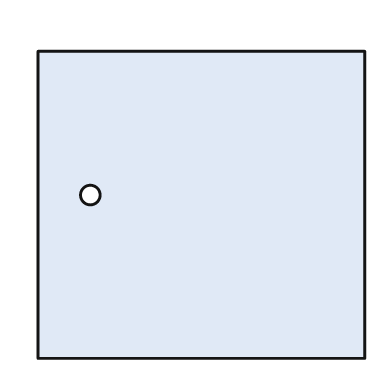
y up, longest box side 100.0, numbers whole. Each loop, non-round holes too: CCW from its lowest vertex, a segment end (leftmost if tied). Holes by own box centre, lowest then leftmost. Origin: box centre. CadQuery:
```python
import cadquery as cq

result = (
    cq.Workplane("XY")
    .moveTo(-50.0, -47.0)
    .lineTo(50.0, -47.0)
    .lineTo(50.0, 47.0)
    .lineTo(-50.0, 47.0)
    .close()
    .moveTo(-34.0, 3.0)
    .circle(3.0)
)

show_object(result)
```